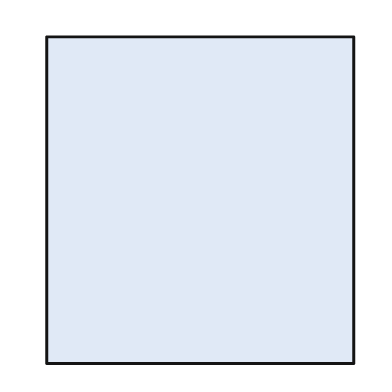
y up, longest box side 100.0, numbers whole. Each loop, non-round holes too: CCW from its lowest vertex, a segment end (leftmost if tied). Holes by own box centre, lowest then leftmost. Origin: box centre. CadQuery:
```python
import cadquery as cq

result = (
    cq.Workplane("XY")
    .moveTo(-47.0, -50.0)
    .lineTo(47.0, -50.0)
    .lineTo(47.0, 50.0)
    .lineTo(-47.0, 50.0)
    .close()
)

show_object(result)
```